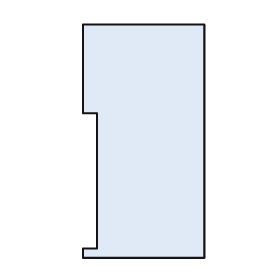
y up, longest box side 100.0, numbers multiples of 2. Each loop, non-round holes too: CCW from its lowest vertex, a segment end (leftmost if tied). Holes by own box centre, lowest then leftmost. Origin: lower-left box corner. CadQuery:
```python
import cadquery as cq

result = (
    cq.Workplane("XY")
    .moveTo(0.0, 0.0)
    .lineTo(52.0, 0.0)
    .lineTo(52.0, 100.0)
    .lineTo(0.0, 100.0)
    .lineTo(0.0, 62.0)
    .lineTo(6.0, 62.0)
    .lineTo(6.0, 4.0)
    .lineTo(0.0, 4.0)
    .close()
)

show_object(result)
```